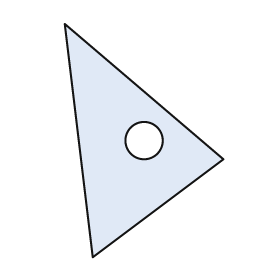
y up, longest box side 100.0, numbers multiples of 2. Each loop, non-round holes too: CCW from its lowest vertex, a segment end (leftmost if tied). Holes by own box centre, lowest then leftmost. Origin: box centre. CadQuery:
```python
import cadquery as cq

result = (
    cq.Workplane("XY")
    .moveTo(-22.0, -50.0)
    .lineTo(34.0, -8.0)
    .lineTo(-34.0, 50.0)
    .close()
    .moveTo(0.0, 0.0)
    .circle(8.0)
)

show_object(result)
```